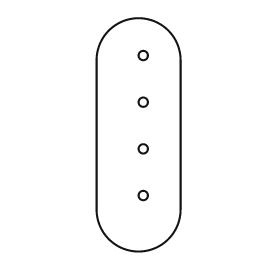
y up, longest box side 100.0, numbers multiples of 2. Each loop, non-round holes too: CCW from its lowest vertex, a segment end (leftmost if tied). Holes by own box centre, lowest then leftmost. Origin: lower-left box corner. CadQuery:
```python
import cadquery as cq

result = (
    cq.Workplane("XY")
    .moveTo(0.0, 18.0)
    .threePointArc((18.0, 0.0), (36.0, 18.0))
    .lineTo(36.0, 82.0)
    .threePointArc((18.0, 100.0), (0.0, 82.0))
    .close()
    .moveTo(20.0, 24.0)
    .circle(2.0)
    .moveTo(20.0, 44.0)
    .circle(2.0)
    .moveTo(20.0, 64.0)
    .circle(2.0)
    .moveTo(20.0, 84.0)
    .circle(2.0)
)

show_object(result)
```